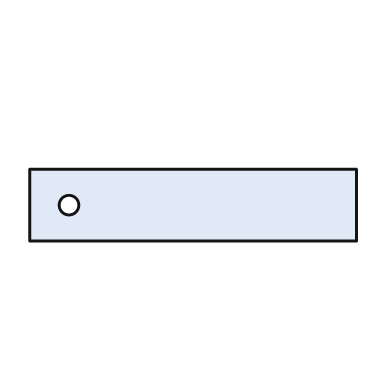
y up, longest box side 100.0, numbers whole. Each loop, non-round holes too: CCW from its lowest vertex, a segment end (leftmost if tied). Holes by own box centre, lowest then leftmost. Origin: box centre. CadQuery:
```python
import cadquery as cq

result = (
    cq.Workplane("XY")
    .moveTo(-50.0, -11.0)
    .lineTo(50.0, -11.0)
    .lineTo(50.0, 11.0)
    .lineTo(-50.0, 11.0)
    .close()
    .moveTo(-38.0, 0.0)
    .circle(3.0)
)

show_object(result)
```